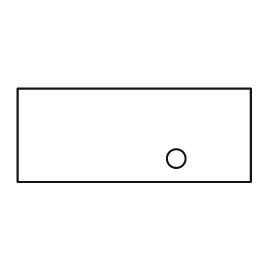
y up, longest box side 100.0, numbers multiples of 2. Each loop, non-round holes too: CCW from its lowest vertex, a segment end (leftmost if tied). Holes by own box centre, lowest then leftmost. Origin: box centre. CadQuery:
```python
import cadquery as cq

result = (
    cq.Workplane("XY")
    .moveTo(-50.0, -20.0)
    .lineTo(50.0, -20.0)
    .lineTo(50.0, 20.0)
    .lineTo(-50.0, 20.0)
    .close()
    .moveTo(18.0, -10.0)
    .circle(4.0)
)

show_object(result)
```